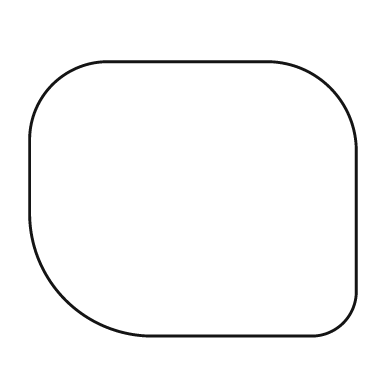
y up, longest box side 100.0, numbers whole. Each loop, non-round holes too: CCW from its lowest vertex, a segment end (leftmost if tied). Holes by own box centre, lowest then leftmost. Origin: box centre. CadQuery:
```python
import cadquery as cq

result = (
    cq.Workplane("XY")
    .moveTo(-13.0, -42.0)
    .lineTo(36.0, -42.0)
    .threePointArc((46.0, -38.0), (50.0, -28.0))
    .lineTo(50.0, 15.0)
    .threePointArc((42.0, 34.0), (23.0, 42.0))
    .lineTo(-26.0, 42.0)
    .threePointArc((-43.0, 35.0), (-50.0, 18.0))
    .lineTo(-50.0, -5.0)
    .threePointArc((-39.0, -31.0), (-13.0, -42.0))
    .close()
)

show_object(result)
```